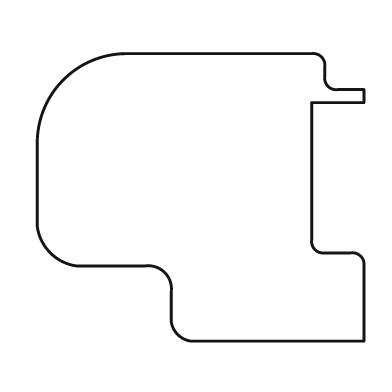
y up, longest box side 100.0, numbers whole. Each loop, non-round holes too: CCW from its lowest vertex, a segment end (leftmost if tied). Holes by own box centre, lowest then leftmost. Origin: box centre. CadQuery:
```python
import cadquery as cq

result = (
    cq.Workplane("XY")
    .moveTo(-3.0, -44.0)
    .lineTo(50.0, -44.0)
    .lineTo(50.0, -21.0)
    .threePointArc((49.0, -18.0), (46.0, -17.0))
    .lineTo(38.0, -17.0)
    .threePointArc((35.0, -16.0), (34.0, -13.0))
    .lineTo(34.0, 29.0)
    .lineTo(50.0, 29.0)
    .lineTo(50.0, 33.0)
    .lineTo(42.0, 33.0)
    .threePointArc((39.0, 34.0), (38.0, 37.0))
    .lineTo(38.0, 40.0)
    .threePointArc((37.0, 43.0), (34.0, 44.0))
    .lineTo(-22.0, 44.0)
    .threePointArc((-42.0, 36.0), (-50.0, 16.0))
    .lineTo(-50.0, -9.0)
    .threePointArc((-46.0, -17.0), (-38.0, -21.0))
    .lineTo(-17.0, -21.0)
    .threePointArc((-11.0, -23.0), (-9.0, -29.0))
    .lineTo(-9.0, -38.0)
    .threePointArc((-7.0, -42.0), (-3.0, -44.0))
    .close()
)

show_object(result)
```